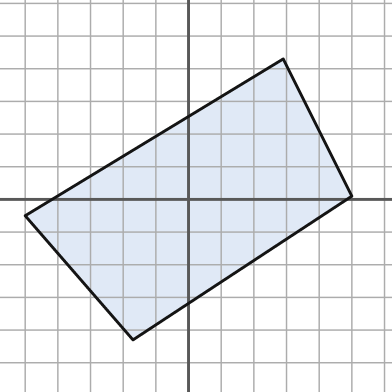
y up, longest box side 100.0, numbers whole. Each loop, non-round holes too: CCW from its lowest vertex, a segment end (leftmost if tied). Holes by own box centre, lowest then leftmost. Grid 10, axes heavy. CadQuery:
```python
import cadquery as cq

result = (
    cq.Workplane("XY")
    .moveTo(-17.0, -43.0)
    .lineTo(50.0, 1.0)
    .lineTo(29.0, 43.0)
    .lineTo(-50.0, -5.0)
    .close()
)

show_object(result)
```